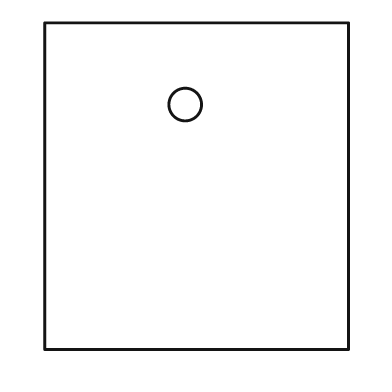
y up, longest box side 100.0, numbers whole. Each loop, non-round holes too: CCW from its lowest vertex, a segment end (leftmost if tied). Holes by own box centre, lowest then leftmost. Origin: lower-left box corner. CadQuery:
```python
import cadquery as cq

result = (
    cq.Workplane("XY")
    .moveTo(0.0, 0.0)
    .lineTo(93.0, 0.0)
    .lineTo(93.0, 100.0)
    .lineTo(0.0, 100.0)
    .close()
    .moveTo(43.0, 75.0)
    .circle(5.0)
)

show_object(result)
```